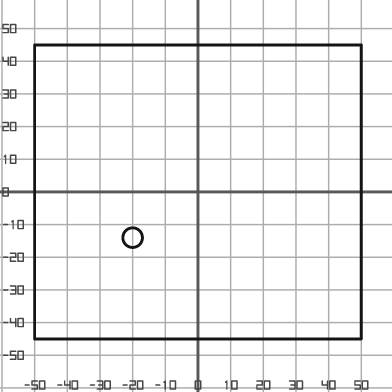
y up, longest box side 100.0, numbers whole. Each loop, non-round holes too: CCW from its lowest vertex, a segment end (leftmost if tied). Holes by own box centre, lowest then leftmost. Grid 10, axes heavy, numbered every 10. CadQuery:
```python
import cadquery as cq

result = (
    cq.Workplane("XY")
    .moveTo(-50.0, -45.0)
    .lineTo(50.0, -45.0)
    .lineTo(50.0, 45.0)
    .lineTo(-50.0, 45.0)
    .close()
    .moveTo(-20.0, -14.0)
    .circle(3.0)
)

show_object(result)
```